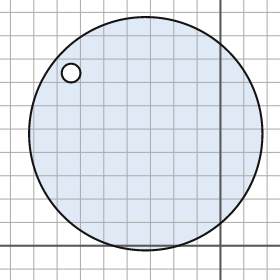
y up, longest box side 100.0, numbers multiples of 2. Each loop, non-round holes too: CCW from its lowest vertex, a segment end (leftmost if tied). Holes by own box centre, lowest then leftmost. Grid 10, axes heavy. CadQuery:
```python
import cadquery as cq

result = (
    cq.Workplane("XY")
    .moveTo(-32.0, 48.0)
    .circle(50.0)
    .moveTo(-64.0, 74.0)
    .circle(4.0)
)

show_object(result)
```